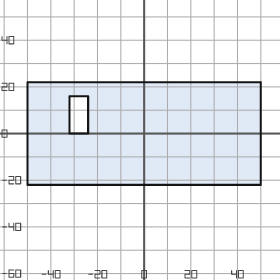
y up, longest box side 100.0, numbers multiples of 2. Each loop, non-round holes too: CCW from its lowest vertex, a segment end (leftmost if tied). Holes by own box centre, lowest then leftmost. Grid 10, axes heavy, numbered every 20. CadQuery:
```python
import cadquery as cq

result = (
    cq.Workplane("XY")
    .moveTo(-50.0, -22.0)
    .lineTo(50.0, -22.0)
    .lineTo(50.0, 22.0)
    .lineTo(-50.0, 22.0)
    .close()
    .moveTo(-32.0, 0.0)
    .lineTo(-24.0, 0.0)
    .lineTo(-24.0, 16.0)
    .lineTo(-32.0, 16.0)
    .close()
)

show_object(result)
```